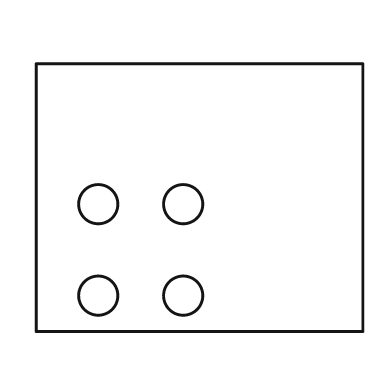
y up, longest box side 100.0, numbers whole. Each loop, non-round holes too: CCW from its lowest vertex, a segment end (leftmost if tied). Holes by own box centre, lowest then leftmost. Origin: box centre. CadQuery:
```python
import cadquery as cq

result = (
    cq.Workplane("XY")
    .moveTo(-50.0, -41.0)
    .lineTo(50.0, -41.0)
    .lineTo(50.0, 41.0)
    .lineTo(-50.0, 41.0)
    .close()
    .moveTo(-31.0, -30.0)
    .circle(6.0)
    .moveTo(-5.0, -30.0)
    .circle(6.0)
    .moveTo(-31.0, -2.0)
    .circle(6.0)
    .moveTo(-5.0, -2.0)
    .circle(6.0)
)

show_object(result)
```